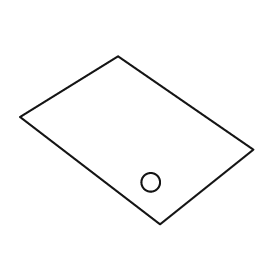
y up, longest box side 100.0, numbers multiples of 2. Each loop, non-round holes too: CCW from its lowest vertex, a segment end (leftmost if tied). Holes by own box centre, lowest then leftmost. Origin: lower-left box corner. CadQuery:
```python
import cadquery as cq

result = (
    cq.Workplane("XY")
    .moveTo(60.0, 0.0)
    .lineTo(100.0, 32.0)
    .lineTo(42.0, 72.0)
    .lineTo(0.0, 46.0)
    .close()
    .moveTo(56.0, 18.0)
    .circle(4.0)
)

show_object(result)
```